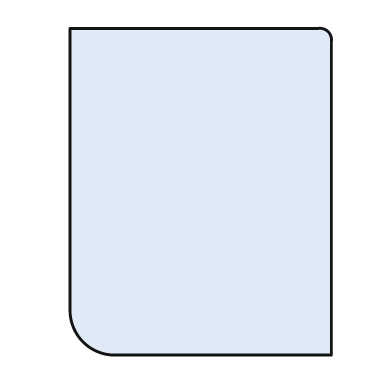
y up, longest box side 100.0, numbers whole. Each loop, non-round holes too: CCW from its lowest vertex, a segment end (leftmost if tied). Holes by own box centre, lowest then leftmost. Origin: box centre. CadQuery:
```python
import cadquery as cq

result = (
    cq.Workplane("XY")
    .moveTo(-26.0, -50.0)
    .lineTo(40.0, -50.0)
    .lineTo(40.0, 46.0)
    .threePointArc((39.0, 49.0), (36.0, 50.0))
    .lineTo(-40.0, 50.0)
    .lineTo(-40.0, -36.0)
    .threePointArc((-36.0, -46.0), (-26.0, -50.0))
    .close()
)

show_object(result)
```